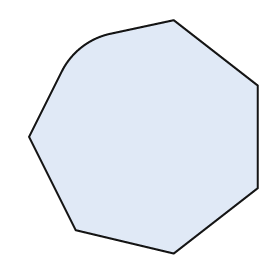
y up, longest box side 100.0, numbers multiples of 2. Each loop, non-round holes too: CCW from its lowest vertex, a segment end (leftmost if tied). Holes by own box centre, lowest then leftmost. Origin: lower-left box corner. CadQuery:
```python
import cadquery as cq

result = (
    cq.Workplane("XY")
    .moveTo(62.0, 0.0)
    .lineTo(98.0, 28.0)
    .lineTo(98.0, 72.0)
    .lineTo(62.0, 100.0)
    .lineTo(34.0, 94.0)
    .threePointArc((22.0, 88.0), (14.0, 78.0))
    .lineTo(0.0, 50.0)
    .lineTo(20.0, 10.0)
    .close()
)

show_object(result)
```